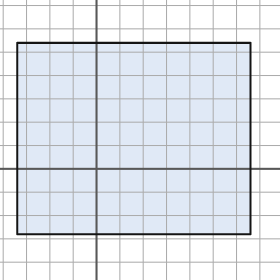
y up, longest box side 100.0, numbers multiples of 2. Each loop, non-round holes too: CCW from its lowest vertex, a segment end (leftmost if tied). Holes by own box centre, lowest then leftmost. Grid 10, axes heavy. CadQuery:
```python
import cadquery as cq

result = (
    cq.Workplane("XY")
    .moveTo(-34.0, -28.0)
    .lineTo(66.0, -28.0)
    .lineTo(66.0, 54.0)
    .lineTo(-34.0, 54.0)
    .close()
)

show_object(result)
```